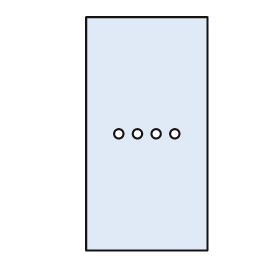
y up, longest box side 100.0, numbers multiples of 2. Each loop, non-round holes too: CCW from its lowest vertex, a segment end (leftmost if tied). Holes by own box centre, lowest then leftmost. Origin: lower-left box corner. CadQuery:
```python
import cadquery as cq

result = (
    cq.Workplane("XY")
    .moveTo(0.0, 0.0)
    .lineTo(52.0, 0.0)
    .lineTo(52.0, 100.0)
    .lineTo(0.0, 100.0)
    .close()
    .moveTo(14.0, 50.0)
    .circle(2.0)
    .moveTo(22.0, 50.0)
    .circle(2.0)
    .moveTo(30.0, 50.0)
    .circle(2.0)
    .moveTo(38.0, 50.0)
    .circle(2.0)
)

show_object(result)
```